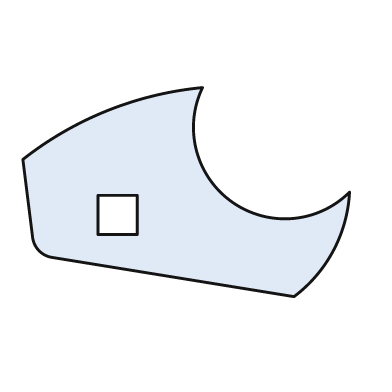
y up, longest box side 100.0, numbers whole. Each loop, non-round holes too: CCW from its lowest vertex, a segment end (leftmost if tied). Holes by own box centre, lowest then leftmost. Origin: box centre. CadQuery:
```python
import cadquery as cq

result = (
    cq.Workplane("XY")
    .moveTo(33.0, -32.0)
    .threePointArc((45.0, -18.0), (50.0, 0.0))
    .threePointArc((14.0, -3.0), (5.0, 32.0))
    .threePointArc((-24.0, 25.0), (-50.0, 10.0))
    .lineTo(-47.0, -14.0)
    .threePointArc((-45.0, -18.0), (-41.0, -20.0))
    .close()
    .moveTo(-27.0, -13.0)
    .lineTo(-15.0, -13.0)
    .lineTo(-15.0, -1.0)
    .lineTo(-27.0, -1.0)
    .close()
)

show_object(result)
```